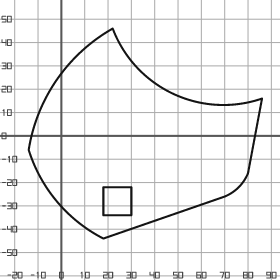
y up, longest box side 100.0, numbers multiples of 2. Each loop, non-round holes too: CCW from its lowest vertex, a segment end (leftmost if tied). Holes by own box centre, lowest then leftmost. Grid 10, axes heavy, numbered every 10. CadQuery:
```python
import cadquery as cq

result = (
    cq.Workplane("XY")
    .moveTo(18.0, -44.0)
    .lineTo(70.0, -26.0)
    .threePointArc((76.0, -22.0), (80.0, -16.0))
    .lineTo(86.0, 16.0)
    .threePointArc((48.0, 18.0), (22.0, 46.0))
    .threePointArc((-2.0, 24.0), (-14.0, -6.0))
    .threePointArc((-2.0, -28.0), (18.0, -44.0))
    .close()
    .moveTo(18.0, -34.0)
    .lineTo(30.0, -34.0)
    .lineTo(30.0, -22.0)
    .lineTo(18.0, -22.0)
    .close()
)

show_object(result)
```